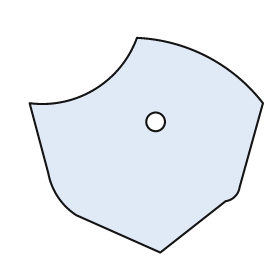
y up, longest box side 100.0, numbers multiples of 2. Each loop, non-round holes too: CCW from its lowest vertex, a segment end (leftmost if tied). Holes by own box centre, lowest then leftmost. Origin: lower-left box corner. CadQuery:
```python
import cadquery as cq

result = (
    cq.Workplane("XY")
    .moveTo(56.0, 0.0)
    .lineTo(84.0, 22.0)
    .threePointArc((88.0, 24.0), (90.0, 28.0))
    .lineTo(100.0, 64.0)
    .threePointArc((76.0, 84.0), (46.0, 92.0))
    .threePointArc((28.0, 70.0), (0.0, 64.0))
    .lineTo(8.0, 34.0)
    .threePointArc((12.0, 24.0), (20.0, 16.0))
    .close()
    .moveTo(54.0, 56.0)
    .circle(4.0)
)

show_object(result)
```